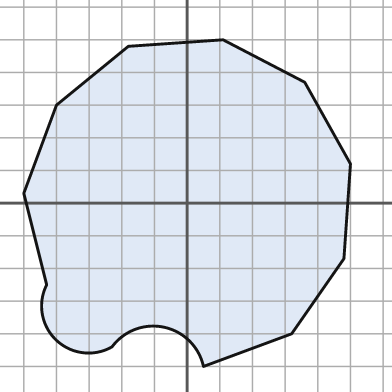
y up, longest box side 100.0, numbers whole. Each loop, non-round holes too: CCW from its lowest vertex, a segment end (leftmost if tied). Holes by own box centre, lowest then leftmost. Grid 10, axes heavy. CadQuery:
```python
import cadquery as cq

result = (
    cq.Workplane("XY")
    .moveTo(5.0, -50.0)
    .lineTo(32.0, -40.0)
    .lineTo(48.0, -17.0)
    .lineTo(50.0, 12.0)
    .lineTo(36.0, 37.0)
    .lineTo(11.0, 50.0)
    .lineTo(-18.0, 48.0)
    .lineTo(-40.0, 30.0)
    .lineTo(-50.0, 3.0)
    .lineTo(-43.0, -25.0)
    .threePointArc((-40.0, -42.0), (-23.0, -44.0))
    .threePointArc((-7.0, -38.0), (5.0, -50.0))
    .close()
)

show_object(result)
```